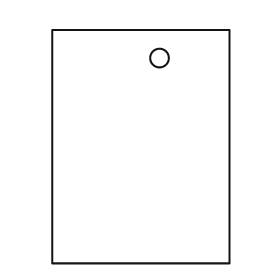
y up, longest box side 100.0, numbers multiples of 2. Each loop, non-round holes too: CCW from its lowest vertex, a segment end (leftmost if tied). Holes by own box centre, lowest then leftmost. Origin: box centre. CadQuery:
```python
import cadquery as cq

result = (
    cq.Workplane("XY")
    .moveTo(-38.0, -50.0)
    .lineTo(38.0, -50.0)
    .lineTo(38.0, 50.0)
    .lineTo(-38.0, 50.0)
    .close()
    .moveTo(8.0, 38.0)
    .circle(4.0)
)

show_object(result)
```